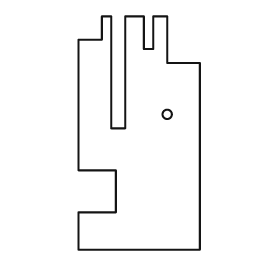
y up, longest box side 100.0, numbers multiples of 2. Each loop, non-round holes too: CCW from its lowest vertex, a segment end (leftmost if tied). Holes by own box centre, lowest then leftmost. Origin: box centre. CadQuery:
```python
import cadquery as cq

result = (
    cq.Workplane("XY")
    .moveTo(-26.0, -50.0)
    .lineTo(26.0, -50.0)
    .lineTo(26.0, 30.0)
    .lineTo(12.0, 30.0)
    .lineTo(12.0, 50.0)
    .lineTo(6.0, 50.0)
    .lineTo(6.0, 36.0)
    .lineTo(2.0, 36.0)
    .lineTo(2.0, 50.0)
    .lineTo(-6.0, 50.0)
    .lineTo(-6.0, 2.0)
    .lineTo(-12.0, 2.0)
    .lineTo(-12.0, 50.0)
    .lineTo(-16.0, 50.0)
    .lineTo(-16.0, 40.0)
    .lineTo(-26.0, 40.0)
    .lineTo(-26.0, -16.0)
    .lineTo(-10.0, -16.0)
    .lineTo(-10.0, -34.0)
    .lineTo(-26.0, -34.0)
    .close()
    .moveTo(12.0, 8.0)
    .circle(2.0)
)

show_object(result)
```